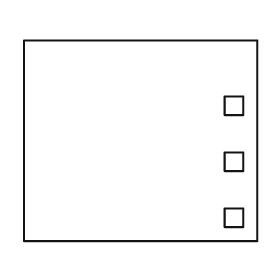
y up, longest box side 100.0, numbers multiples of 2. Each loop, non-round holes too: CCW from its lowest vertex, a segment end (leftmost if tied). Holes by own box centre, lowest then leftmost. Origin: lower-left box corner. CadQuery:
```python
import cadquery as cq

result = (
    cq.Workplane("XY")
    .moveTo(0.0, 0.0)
    .lineTo(100.0, 0.0)
    .lineTo(100.0, 86.0)
    .lineTo(0.0, 86.0)
    .close()
    .moveTo(86.0, 6.0)
    .lineTo(94.0, 6.0)
    .lineTo(94.0, 14.0)
    .lineTo(86.0, 14.0)
    .close()
    .moveTo(86.0, 30.0)
    .lineTo(94.0, 30.0)
    .lineTo(94.0, 38.0)
    .lineTo(86.0, 38.0)
    .close()
    .moveTo(86.0, 54.0)
    .lineTo(94.0, 54.0)
    .lineTo(94.0, 62.0)
    .lineTo(86.0, 62.0)
    .close()
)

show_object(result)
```